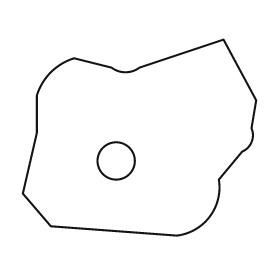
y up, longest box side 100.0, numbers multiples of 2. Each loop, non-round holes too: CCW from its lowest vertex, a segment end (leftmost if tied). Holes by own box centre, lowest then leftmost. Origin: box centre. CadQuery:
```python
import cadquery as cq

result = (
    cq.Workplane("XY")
    .moveTo(16.0, -42.0)
    .threePointArc((30.0, -34.0), (34.0, -18.0))
    .lineTo(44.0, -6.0)
    .threePointArc((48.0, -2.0), (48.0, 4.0))
    .lineTo(50.0, 16.0)
    .lineTo(36.0, 42.0)
    .lineTo(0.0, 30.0)
    .threePointArc((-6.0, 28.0), (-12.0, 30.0))
    .lineTo(-28.0, 34.0)
    .threePointArc((-38.0, 28.0), (-44.0, 18.0))
    .lineTo(-44.0, 2.0)
    .lineTo(-50.0, -24.0)
    .lineTo(-38.0, -38.0)
    .close()
    .moveTo(-10.0, -10.0)
    .circle(8.0)
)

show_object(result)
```